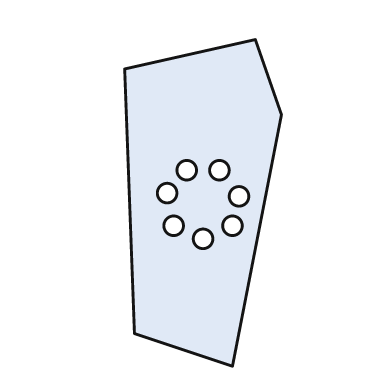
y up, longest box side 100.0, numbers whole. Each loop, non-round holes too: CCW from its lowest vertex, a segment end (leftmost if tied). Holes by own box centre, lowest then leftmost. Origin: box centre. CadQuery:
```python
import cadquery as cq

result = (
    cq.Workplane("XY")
    .moveTo(9.0, -50.0)
    .lineTo(24.0, 27.0)
    .lineTo(16.0, 50.0)
    .lineTo(-24.0, 41.0)
    .lineTo(-21.0, -40.0)
    .close()
    .moveTo(0.0, -11.0)
    .circle(3.0)
    .moveTo(-9.0, -7.0)
    .circle(3.0)
    .moveTo(9.0, -7.0)
    .circle(3.0)
    .moveTo(11.0, 2.0)
    .circle(3.0)
    .moveTo(-11.0, 3.0)
    .circle(3.0)
    .moveTo(-5.0, 10.0)
    .circle(3.0)
    .moveTo(5.0, 10.0)
    .circle(3.0)
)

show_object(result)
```